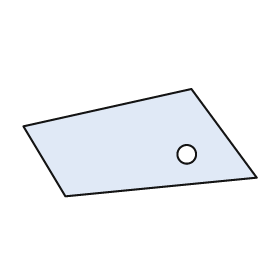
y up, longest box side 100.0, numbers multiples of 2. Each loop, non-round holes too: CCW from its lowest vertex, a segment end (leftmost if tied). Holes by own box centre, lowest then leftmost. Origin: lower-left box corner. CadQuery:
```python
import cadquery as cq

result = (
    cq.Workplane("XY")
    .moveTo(18.0, 0.0)
    .lineTo(100.0, 8.0)
    .lineTo(72.0, 46.0)
    .lineTo(0.0, 30.0)
    .close()
    .moveTo(70.0, 18.0)
    .circle(4.0)
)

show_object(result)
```